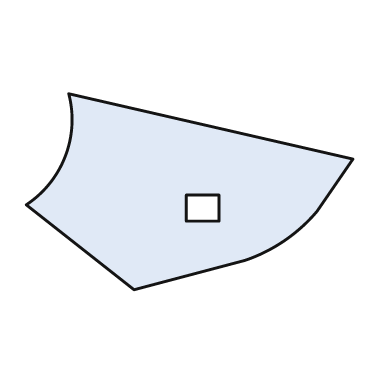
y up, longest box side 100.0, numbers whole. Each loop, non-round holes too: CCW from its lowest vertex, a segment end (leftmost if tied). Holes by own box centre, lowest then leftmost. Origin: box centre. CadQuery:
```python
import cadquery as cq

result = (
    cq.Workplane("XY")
    .moveTo(-17.0, -30.0)
    .lineTo(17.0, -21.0)
    .threePointArc((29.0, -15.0), (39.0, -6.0))
    .lineTo(50.0, 10.0)
    .lineTo(-37.0, 30.0)
    .threePointArc((-38.0, 11.0), (-50.0, -4.0))
    .close()
    .moveTo(-1.0, -9.0)
    .lineTo(9.0, -9.0)
    .lineTo(9.0, -1.0)
    .lineTo(-1.0, -1.0)
    .close()
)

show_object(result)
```